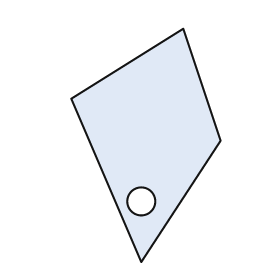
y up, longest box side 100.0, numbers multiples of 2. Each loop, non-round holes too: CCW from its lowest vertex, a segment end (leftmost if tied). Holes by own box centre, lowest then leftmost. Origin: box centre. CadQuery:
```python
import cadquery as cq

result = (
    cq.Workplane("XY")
    .moveTo(-2.0, -50.0)
    .lineTo(32.0, 2.0)
    .lineTo(16.0, 50.0)
    .lineTo(-32.0, 20.0)
    .close()
    .moveTo(-2.0, -24.0)
    .circle(6.0)
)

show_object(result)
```